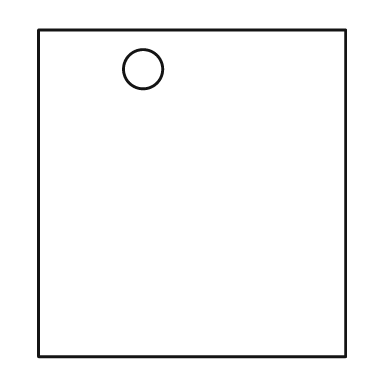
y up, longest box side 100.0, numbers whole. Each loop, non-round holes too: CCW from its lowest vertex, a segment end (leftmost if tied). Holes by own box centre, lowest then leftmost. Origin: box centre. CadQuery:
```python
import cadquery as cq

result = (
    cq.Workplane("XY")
    .moveTo(-47.0, -50.0)
    .lineTo(47.0, -50.0)
    .lineTo(47.0, 50.0)
    .lineTo(-47.0, 50.0)
    .close()
    .moveTo(-15.0, 38.0)
    .circle(6.0)
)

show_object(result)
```